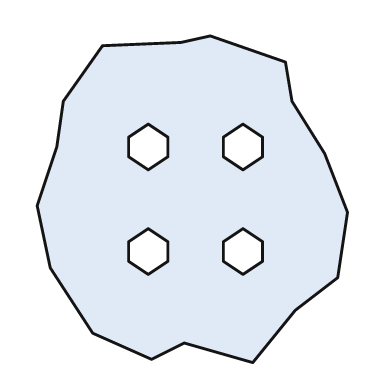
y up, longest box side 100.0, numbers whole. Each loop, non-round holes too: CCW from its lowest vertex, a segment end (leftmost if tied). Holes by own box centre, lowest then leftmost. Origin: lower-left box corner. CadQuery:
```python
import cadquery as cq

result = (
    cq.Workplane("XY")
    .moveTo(66.0, 0.0)
    .lineTo(79.0, 16.0)
    .lineTo(92.0, 26.0)
    .lineTo(95.0, 46.0)
    .lineTo(88.0, 64.0)
    .lineTo(78.0, 80.0)
    .lineTo(76.0, 92.0)
    .lineTo(53.0, 100.0)
    .lineTo(44.0, 98.0)
    .lineTo(20.0, 97.0)
    .lineTo(8.0, 80.0)
    .lineTo(6.0, 66.0)
    .lineTo(0.0, 48.0)
    .lineTo(4.0, 29.0)
    .lineTo(17.0, 9.0)
    .lineTo(35.0, 1.0)
    .lineTo(45.0, 6.0)
    .close()
    .moveTo(34.0, 27.0)
    .lineTo(40.0, 31.0)
    .lineTo(40.0, 37.0)
    .lineTo(34.0, 41.0)
    .lineTo(28.0, 37.0)
    .lineTo(28.0, 31.0)
    .close()
    .moveTo(63.0, 27.0)
    .lineTo(69.0, 31.0)
    .lineTo(69.0, 37.0)
    .lineTo(63.0, 41.0)
    .lineTo(57.0, 37.0)
    .lineTo(57.0, 31.0)
    .close()
    .moveTo(34.0, 59.0)
    .lineTo(40.0, 63.0)
    .lineTo(40.0, 69.0)
    .lineTo(34.0, 73.0)
    .lineTo(28.0, 69.0)
    .lineTo(28.0, 63.0)
    .close()
    .moveTo(63.0, 59.0)
    .lineTo(69.0, 63.0)
    .lineTo(69.0, 69.0)
    .lineTo(63.0, 73.0)
    .lineTo(57.0, 69.0)
    .lineTo(57.0, 63.0)
    .close()
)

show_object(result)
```